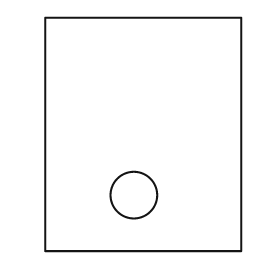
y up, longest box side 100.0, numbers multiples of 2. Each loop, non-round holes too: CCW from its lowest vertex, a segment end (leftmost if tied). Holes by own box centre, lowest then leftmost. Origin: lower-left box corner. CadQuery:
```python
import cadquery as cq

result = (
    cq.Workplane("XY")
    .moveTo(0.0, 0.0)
    .lineTo(84.0, 0.0)
    .lineTo(84.0, 100.0)
    .lineTo(0.0, 100.0)
    .close()
    .moveTo(38.0, 24.0)
    .circle(10.0)
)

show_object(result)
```